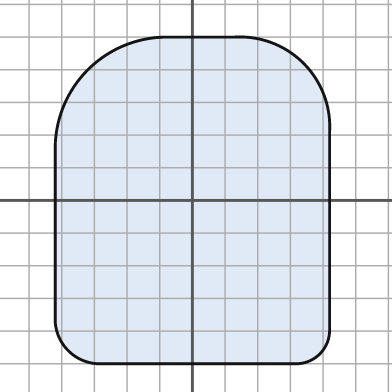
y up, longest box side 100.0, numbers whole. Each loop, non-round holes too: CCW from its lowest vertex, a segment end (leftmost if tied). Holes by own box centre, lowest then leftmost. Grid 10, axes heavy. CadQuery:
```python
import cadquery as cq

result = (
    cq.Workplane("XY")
    .moveTo(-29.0, -50.0)
    .lineTo(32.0, -50.0)
    .threePointArc((39.0, -47.0), (42.0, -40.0))
    .lineTo(42.0, 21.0)
    .threePointArc((34.0, 42.0), (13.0, 50.0))
    .lineTo(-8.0, 50.0)
    .threePointArc((-32.0, 40.0), (-42.0, 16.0))
    .lineTo(-42.0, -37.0)
    .threePointArc((-38.0, -46.0), (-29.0, -50.0))
    .close()
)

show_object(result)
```